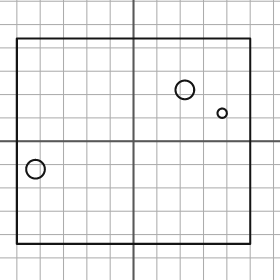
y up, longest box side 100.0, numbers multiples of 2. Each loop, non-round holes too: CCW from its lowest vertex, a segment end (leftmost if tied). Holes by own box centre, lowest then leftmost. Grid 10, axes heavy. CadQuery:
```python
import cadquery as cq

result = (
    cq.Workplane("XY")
    .moveTo(-50.0, -44.0)
    .lineTo(50.0, -44.0)
    .lineTo(50.0, 44.0)
    .lineTo(-50.0, 44.0)
    .close()
    .moveTo(-42.0, -12.0)
    .circle(4.0)
    .moveTo(38.0, 12.0)
    .circle(2.0)
    .moveTo(22.0, 22.0)
    .circle(4.0)
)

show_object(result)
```